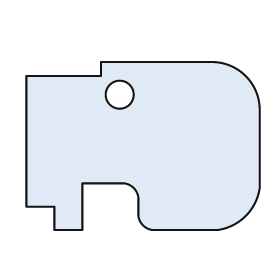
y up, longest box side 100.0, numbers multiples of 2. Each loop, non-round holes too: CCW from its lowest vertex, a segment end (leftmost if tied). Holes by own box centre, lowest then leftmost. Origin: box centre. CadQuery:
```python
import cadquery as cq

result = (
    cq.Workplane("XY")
    .moveTo(-38.0, -36.0)
    .lineTo(-26.0, -36.0)
    .lineTo(-26.0, -16.0)
    .lineTo(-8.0, -16.0)
    .threePointArc((-4.0, -18.0), (-2.0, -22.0))
    .lineTo(-2.0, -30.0)
    .threePointArc((0.0, -34.0), (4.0, -36.0))
    .lineTo(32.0, -36.0)
    .threePointArc((44.0, -30.0), (50.0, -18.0))
    .lineTo(50.0, 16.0)
    .threePointArc((44.0, 30.0), (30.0, 36.0))
    .lineTo(-18.0, 36.0)
    .lineTo(-18.0, 30.0)
    .lineTo(-50.0, 30.0)
    .lineTo(-50.0, -26.0)
    .lineTo(-38.0, -26.0)
    .close()
    .moveTo(-10.0, 22.0)
    .circle(6.0)
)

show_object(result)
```